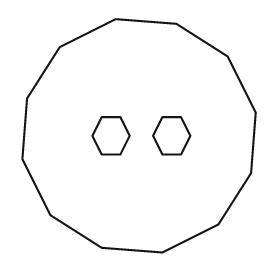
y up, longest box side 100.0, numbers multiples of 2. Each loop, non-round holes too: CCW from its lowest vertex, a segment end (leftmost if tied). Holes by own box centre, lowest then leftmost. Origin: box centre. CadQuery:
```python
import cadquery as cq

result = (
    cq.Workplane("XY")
    .moveTo(10.0, -50.0)
    .lineTo(34.0, -38.0)
    .lineTo(48.0, -16.0)
    .lineTo(50.0, 10.0)
    .lineTo(38.0, 34.0)
    .lineTo(16.0, 48.0)
    .lineTo(-10.0, 50.0)
    .lineTo(-34.0, 38.0)
    .lineTo(-48.0, 16.0)
    .lineTo(-50.0, -10.0)
    .lineTo(-38.0, -34.0)
    .lineTo(-16.0, -48.0)
    .close()
    .moveTo(-16.0, -8.0)
    .lineTo(-8.0, -8.0)
    .lineTo(-4.0, 0.0)
    .lineTo(-8.0, 8.0)
    .lineTo(-16.0, 8.0)
    .lineTo(-20.0, 0.0)
    .close()
    .moveTo(10.0, -8.0)
    .lineTo(18.0, -8.0)
    .lineTo(22.0, 0.0)
    .lineTo(18.0, 8.0)
    .lineTo(10.0, 8.0)
    .lineTo(6.0, 0.0)
    .close()
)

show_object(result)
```